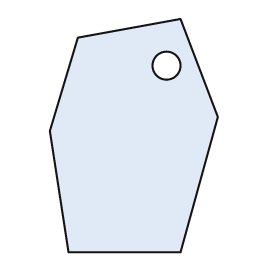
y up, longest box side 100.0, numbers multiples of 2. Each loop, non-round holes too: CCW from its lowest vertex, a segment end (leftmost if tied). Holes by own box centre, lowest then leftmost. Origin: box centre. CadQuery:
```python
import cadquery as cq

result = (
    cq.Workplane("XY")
    .moveTo(-28.0, -50.0)
    .lineTo(20.0, -50.0)
    .lineTo(36.0, 8.0)
    .lineTo(20.0, 50.0)
    .lineTo(-24.0, 42.0)
    .lineTo(-36.0, 2.0)
    .close()
    .moveTo(14.0, 30.0)
    .circle(6.0)
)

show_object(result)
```